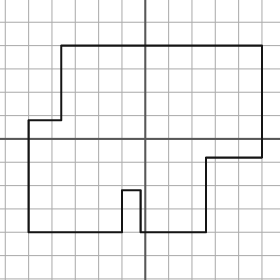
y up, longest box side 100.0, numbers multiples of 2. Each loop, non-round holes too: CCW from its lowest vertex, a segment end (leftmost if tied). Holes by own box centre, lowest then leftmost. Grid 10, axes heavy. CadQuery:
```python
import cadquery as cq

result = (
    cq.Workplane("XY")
    .moveTo(-50.0, -40.0)
    .lineTo(-10.0, -40.0)
    .lineTo(-10.0, -22.0)
    .lineTo(-2.0, -22.0)
    .lineTo(-2.0, -40.0)
    .lineTo(26.0, -40.0)
    .lineTo(26.0, -8.0)
    .lineTo(50.0, -8.0)
    .lineTo(50.0, 40.0)
    .lineTo(-36.0, 40.0)
    .lineTo(-36.0, 8.0)
    .lineTo(-50.0, 8.0)
    .close()
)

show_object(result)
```